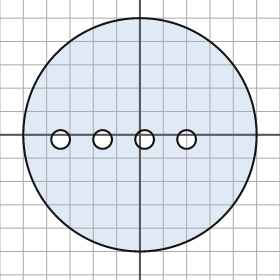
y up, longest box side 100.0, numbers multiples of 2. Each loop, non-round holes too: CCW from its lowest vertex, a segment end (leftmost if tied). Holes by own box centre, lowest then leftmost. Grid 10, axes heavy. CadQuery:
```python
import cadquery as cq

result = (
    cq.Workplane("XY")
    .moveTo(0.0, 0.0)
    .circle(50.0)
    .moveTo(-34.0, -2.0)
    .circle(4.0)
    .moveTo(-16.0, -2.0)
    .circle(4.0)
    .moveTo(2.0, -2.0)
    .circle(4.0)
    .moveTo(20.0, -2.0)
    .circle(4.0)
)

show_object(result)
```